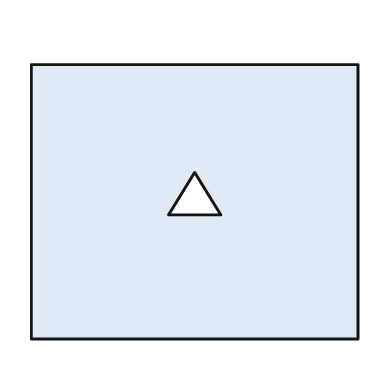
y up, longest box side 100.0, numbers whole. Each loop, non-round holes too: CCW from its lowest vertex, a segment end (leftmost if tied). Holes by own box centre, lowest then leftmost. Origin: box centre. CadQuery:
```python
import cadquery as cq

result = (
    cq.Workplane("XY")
    .moveTo(-50.0, -42.0)
    .lineTo(50.0, -42.0)
    .lineTo(50.0, 42.0)
    .lineTo(-50.0, 42.0)
    .close()
    .moveTo(-8.0, -4.0)
    .lineTo(8.0, -4.0)
    .lineTo(0.0, 9.0)
    .close()
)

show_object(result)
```